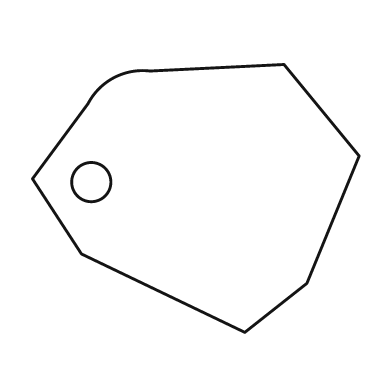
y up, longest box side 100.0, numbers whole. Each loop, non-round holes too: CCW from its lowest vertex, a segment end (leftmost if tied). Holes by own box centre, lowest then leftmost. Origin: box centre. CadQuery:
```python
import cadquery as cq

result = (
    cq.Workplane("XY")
    .moveTo(15.0, -41.0)
    .lineTo(34.0, -26.0)
    .lineTo(50.0, 13.0)
    .lineTo(27.0, 41.0)
    .lineTo(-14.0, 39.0)
    .threePointArc((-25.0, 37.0), (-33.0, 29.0))
    .lineTo(-50.0, 6.0)
    .lineTo(-35.0, -17.0)
    .close()
    .moveTo(-32.0, 5.0)
    .circle(6.0)
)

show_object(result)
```